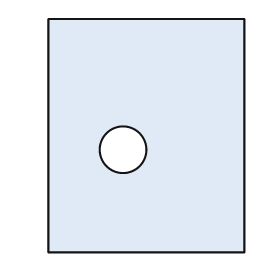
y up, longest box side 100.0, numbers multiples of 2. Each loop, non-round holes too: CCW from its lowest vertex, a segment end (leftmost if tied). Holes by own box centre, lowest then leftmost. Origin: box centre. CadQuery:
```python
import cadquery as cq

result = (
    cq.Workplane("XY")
    .moveTo(-42.0, -50.0)
    .lineTo(42.0, -50.0)
    .lineTo(42.0, 50.0)
    .lineTo(-42.0, 50.0)
    .close()
    .moveTo(-10.0, -6.0)
    .circle(10.0)
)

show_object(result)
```